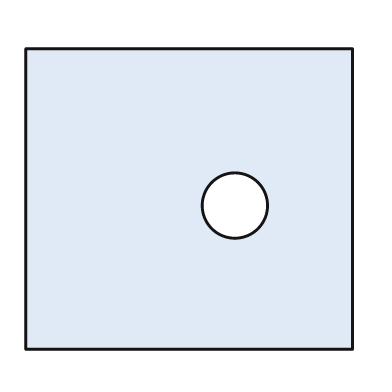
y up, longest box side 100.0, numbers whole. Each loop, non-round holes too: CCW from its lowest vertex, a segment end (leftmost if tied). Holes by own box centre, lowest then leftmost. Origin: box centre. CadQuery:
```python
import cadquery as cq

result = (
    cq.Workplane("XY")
    .moveTo(-50.0, -46.0)
    .lineTo(50.0, -46.0)
    .lineTo(50.0, 46.0)
    .lineTo(-50.0, 46.0)
    .close()
    .moveTo(14.0, -2.0)
    .circle(10.0)
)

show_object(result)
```